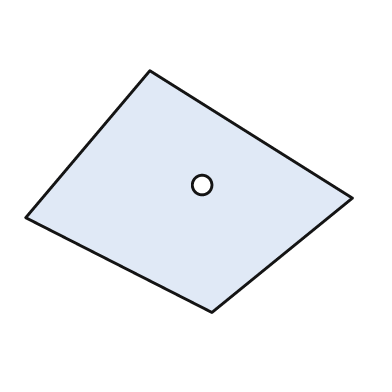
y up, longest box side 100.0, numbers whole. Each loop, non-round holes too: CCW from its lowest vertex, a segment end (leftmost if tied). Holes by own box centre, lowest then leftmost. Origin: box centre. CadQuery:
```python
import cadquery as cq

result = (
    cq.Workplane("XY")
    .moveTo(7.0, -37.0)
    .lineTo(50.0, -2.0)
    .lineTo(-12.0, 37.0)
    .lineTo(-50.0, -8.0)
    .close()
    .moveTo(4.0, 2.0)
    .circle(3.0)
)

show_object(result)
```